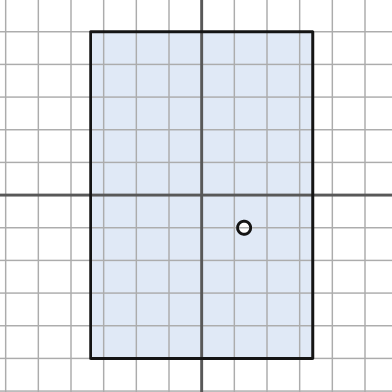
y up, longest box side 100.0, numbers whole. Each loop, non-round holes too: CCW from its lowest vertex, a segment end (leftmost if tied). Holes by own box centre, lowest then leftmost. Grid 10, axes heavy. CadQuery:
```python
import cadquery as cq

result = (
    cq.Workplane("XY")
    .moveTo(-34.0, -50.0)
    .lineTo(34.0, -50.0)
    .lineTo(34.0, 50.0)
    .lineTo(-34.0, 50.0)
    .close()
    .moveTo(13.0, -10.0)
    .circle(2.0)
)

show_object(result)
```